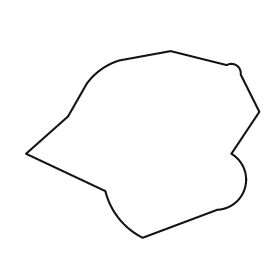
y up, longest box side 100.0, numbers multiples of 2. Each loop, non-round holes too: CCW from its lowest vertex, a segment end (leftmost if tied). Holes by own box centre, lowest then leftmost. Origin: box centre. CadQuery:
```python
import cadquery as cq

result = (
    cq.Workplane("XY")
    .moveTo(0.0, -40.0)
    .lineTo(32.0, -28.0)
    .threePointArc((44.0, -18.0), (38.0, -4.0))
    .lineTo(50.0, 14.0)
    .lineTo(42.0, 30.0)
    .threePointArc((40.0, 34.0), (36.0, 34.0))
    .lineTo(12.0, 40.0)
    .lineTo(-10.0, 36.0)
    .threePointArc((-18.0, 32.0), (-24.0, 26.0))
    .lineTo(-32.0, 12.0)
    .lineTo(-50.0, -4.0)
    .lineTo(-16.0, -20.0)
    .threePointArc((-10.0, -32.0), (0.0, -40.0))
    .close()
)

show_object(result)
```